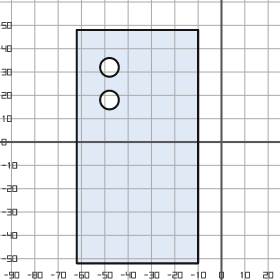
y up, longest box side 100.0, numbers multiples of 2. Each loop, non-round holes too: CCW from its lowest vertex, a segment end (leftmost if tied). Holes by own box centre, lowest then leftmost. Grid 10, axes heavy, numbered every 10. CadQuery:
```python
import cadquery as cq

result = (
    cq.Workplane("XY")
    .moveTo(-62.0, -52.0)
    .lineTo(-10.0, -52.0)
    .lineTo(-10.0, 48.0)
    .lineTo(-62.0, 48.0)
    .close()
    .moveTo(-48.0, 18.0)
    .circle(4.0)
    .moveTo(-48.0, 32.0)
    .circle(4.0)
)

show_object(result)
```